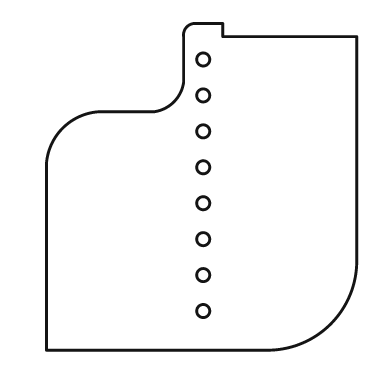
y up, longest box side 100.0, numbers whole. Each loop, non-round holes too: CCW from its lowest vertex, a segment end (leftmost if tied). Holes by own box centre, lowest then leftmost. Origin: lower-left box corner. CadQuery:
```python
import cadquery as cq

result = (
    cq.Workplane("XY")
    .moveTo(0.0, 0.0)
    .lineTo(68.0, 0.0)
    .threePointArc((87.0, 8.0), (95.0, 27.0))
    .lineTo(95.0, 96.0)
    .lineTo(54.0, 96.0)
    .lineTo(54.0, 100.0)
    .lineTo(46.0, 100.0)
    .threePointArc((43.0, 99.0), (42.0, 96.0))
    .lineTo(42.0, 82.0)
    .threePointArc((39.0, 76.0), (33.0, 73.0))
    .lineTo(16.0, 73.0)
    .threePointArc((5.0, 68.0), (0.0, 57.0))
    .close()
    .moveTo(48.0, 12.0)
    .circle(2.0)
    .moveTo(48.0, 23.0)
    .circle(2.0)
    .moveTo(48.0, 34.0)
    .circle(2.0)
    .moveTo(48.0, 45.0)
    .circle(2.0)
    .moveTo(48.0, 56.0)
    .circle(2.0)
    .moveTo(48.0, 67.0)
    .circle(2.0)
    .moveTo(48.0, 78.0)
    .circle(2.0)
    .moveTo(48.0, 89.0)
    .circle(2.0)
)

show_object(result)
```